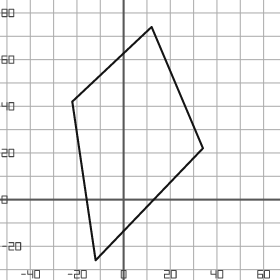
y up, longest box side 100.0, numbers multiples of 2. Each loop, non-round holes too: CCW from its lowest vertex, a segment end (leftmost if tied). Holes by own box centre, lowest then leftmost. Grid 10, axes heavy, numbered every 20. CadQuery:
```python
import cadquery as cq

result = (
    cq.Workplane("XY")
    .moveTo(-12.0, -26.0)
    .lineTo(34.0, 22.0)
    .lineTo(12.0, 74.0)
    .lineTo(-22.0, 42.0)
    .close()
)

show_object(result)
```